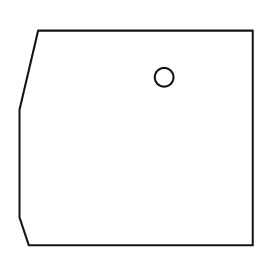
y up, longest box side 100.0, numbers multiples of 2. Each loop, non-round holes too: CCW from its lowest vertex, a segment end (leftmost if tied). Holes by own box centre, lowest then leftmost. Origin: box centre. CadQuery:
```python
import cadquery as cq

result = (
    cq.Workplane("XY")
    .moveTo(-46.0, -46.0)
    .lineTo(50.0, -46.0)
    .lineTo(50.0, 46.0)
    .lineTo(-42.0, 46.0)
    .lineTo(-50.0, 12.0)
    .lineTo(-50.0, -34.0)
    .close()
    .moveTo(12.0, 26.0)
    .circle(4.0)
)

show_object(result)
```